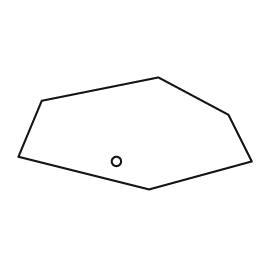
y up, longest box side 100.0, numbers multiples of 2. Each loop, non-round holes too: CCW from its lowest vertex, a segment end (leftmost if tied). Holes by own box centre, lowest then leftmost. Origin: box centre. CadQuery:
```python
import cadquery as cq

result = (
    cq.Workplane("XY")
    .moveTo(6.0, -24.0)
    .lineTo(50.0, -12.0)
    .lineTo(40.0, 8.0)
    .lineTo(10.0, 24.0)
    .lineTo(-40.0, 14.0)
    .lineTo(-50.0, -10.0)
    .close()
    .moveTo(-8.0, -12.0)
    .circle(2.0)
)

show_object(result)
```